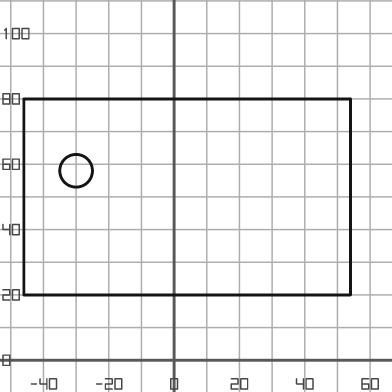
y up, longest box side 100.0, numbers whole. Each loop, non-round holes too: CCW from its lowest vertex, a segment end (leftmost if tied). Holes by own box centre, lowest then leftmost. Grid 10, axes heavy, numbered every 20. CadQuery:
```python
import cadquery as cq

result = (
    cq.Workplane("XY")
    .moveTo(-46.0, 20.0)
    .lineTo(54.0, 20.0)
    .lineTo(54.0, 80.0)
    .lineTo(-46.0, 80.0)
    .close()
    .moveTo(-30.0, 58.0)
    .circle(5.0)
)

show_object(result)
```